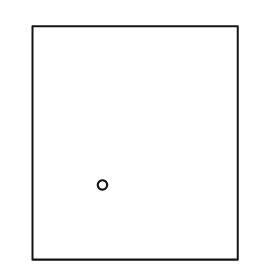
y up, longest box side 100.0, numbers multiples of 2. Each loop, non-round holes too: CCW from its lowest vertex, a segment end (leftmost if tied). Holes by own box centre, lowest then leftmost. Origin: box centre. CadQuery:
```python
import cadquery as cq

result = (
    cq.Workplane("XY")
    .moveTo(-44.0, -50.0)
    .lineTo(44.0, -50.0)
    .lineTo(44.0, 50.0)
    .lineTo(-44.0, 50.0)
    .close()
    .moveTo(-14.0, -18.0)
    .circle(2.0)
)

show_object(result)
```